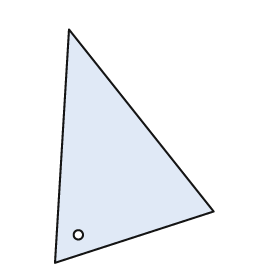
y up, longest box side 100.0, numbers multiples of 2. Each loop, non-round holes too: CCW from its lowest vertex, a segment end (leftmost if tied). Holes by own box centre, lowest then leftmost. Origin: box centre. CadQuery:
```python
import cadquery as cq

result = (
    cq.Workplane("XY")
    .moveTo(-34.0, -50.0)
    .lineTo(34.0, -28.0)
    .lineTo(-28.0, 50.0)
    .close()
    .moveTo(-24.0, -38.0)
    .circle(2.0)
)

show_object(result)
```